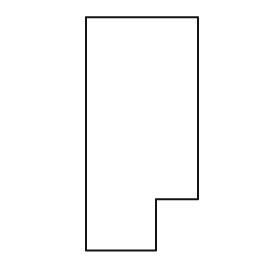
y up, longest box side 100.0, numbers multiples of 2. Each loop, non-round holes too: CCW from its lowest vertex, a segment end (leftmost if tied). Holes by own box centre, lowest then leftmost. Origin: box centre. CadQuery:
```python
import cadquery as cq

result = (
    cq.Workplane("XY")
    .moveTo(-24.0, -50.0)
    .lineTo(6.0, -50.0)
    .lineTo(6.0, -28.0)
    .lineTo(24.0, -28.0)
    .lineTo(24.0, 50.0)
    .lineTo(-24.0, 50.0)
    .close()
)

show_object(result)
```